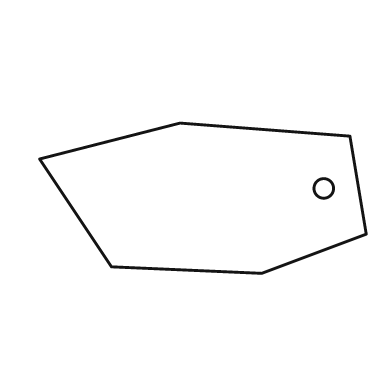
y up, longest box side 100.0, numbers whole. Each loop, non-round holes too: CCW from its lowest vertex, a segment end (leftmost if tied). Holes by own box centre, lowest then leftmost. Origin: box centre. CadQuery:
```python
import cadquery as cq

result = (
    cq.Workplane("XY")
    .moveTo(18.0, -23.0)
    .lineTo(50.0, -11.0)
    .lineTo(45.0, 19.0)
    .lineTo(-7.0, 23.0)
    .lineTo(-50.0, 12.0)
    .lineTo(-28.0, -21.0)
    .close()
    .moveTo(37.0, 3.0)
    .circle(3.0)
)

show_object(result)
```